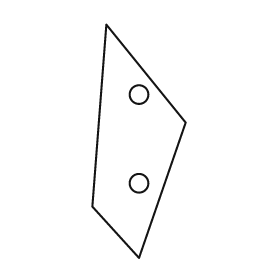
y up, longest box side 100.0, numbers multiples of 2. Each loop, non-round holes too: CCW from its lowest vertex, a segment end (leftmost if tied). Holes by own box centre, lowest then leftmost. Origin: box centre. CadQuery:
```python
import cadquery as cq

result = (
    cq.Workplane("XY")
    .moveTo(0.0, -50.0)
    .lineTo(20.0, 8.0)
    .lineTo(-14.0, 50.0)
    .lineTo(-20.0, -28.0)
    .close()
    .moveTo(0.0, -18.0)
    .circle(4.0)
    .moveTo(0.0, 20.0)
    .circle(4.0)
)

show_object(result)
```